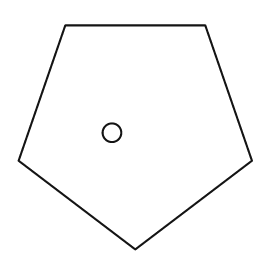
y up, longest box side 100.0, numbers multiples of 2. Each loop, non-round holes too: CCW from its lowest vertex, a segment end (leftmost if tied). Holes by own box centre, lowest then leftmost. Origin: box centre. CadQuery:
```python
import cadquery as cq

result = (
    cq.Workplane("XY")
    .moveTo(0.0, -48.0)
    .lineTo(50.0, -10.0)
    .lineTo(30.0, 48.0)
    .lineTo(-30.0, 48.0)
    .lineTo(-50.0, -10.0)
    .close()
    .moveTo(-10.0, 2.0)
    .circle(4.0)
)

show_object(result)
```